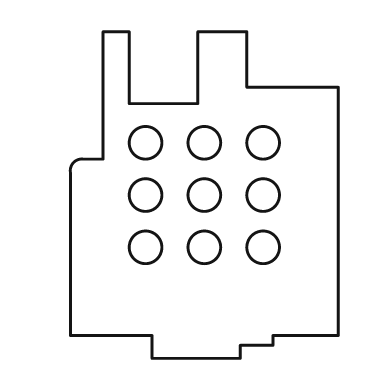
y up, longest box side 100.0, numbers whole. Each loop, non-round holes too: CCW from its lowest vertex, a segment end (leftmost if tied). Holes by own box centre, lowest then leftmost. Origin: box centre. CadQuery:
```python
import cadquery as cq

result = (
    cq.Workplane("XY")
    .moveTo(-16.0, -50.0)
    .lineTo(11.0, -50.0)
    .lineTo(11.0, -46.0)
    .lineTo(21.0, -46.0)
    .lineTo(21.0, -43.0)
    .lineTo(41.0, -43.0)
    .lineTo(41.0, 33.0)
    .lineTo(13.0, 33.0)
    .lineTo(13.0, 50.0)
    .lineTo(-2.0, 50.0)
    .lineTo(-2.0, 28.0)
    .lineTo(-23.0, 28.0)
    .lineTo(-23.0, 50.0)
    .lineTo(-31.0, 50.0)
    .lineTo(-31.0, 11.0)
    .lineTo(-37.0, 11.0)
    .threePointArc((-40.0, 10.0), (-41.0, 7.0))
    .lineTo(-41.0, -43.0)
    .lineTo(-16.0, -43.0)
    .close()
    .moveTo(-18.0, -16.0)
    .circle(5.0)
    .moveTo(0.0, -16.0)
    .circle(5.0)
    .moveTo(18.0, -16.0)
    .circle(5.0)
    .moveTo(-18.0, 0.0)
    .circle(5.0)
    .moveTo(0.0, 0.0)
    .circle(5.0)
    .moveTo(18.0, 0.0)
    .circle(5.0)
    .moveTo(-18.0, 16.0)
    .circle(5.0)
    .moveTo(0.0, 16.0)
    .circle(5.0)
    .moveTo(18.0, 16.0)
    .circle(5.0)
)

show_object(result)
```